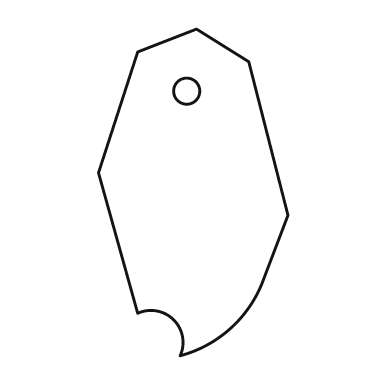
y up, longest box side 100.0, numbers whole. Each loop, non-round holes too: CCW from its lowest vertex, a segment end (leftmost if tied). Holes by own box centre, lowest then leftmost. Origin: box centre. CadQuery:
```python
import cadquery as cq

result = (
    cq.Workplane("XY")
    .moveTo(-4.0, -50.0)
    .threePointArc((11.0, -42.0), (21.0, -28.0))
    .lineTo(29.0, -7.0)
    .lineTo(17.0, 40.0)
    .lineTo(1.0, 50.0)
    .lineTo(-17.0, 43.0)
    .lineTo(-29.0, 6.0)
    .lineTo(-17.0, -37.0)
    .threePointArc((-6.0, -39.0), (-4.0, -50.0))
    .close()
    .moveTo(-2.0, 31.0)
    .circle(4.0)
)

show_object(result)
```